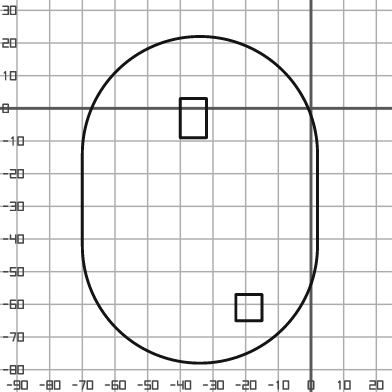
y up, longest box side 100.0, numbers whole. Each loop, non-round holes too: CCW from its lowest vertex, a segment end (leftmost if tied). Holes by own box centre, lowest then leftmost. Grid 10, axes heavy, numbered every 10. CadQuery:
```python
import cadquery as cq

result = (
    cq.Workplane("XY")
    .moveTo(-70.0, -42.0)
    .threePointArc((-34.0, -78.0), (2.0, -42.0))
    .lineTo(2.0, -14.0)
    .threePointArc((-34.0, 22.0), (-70.0, -14.0))
    .close()
    .moveTo(-23.0, -65.0)
    .lineTo(-15.0, -65.0)
    .lineTo(-15.0, -57.0)
    .lineTo(-23.0, -57.0)
    .close()
    .moveTo(-40.0, -9.0)
    .lineTo(-32.0, -9.0)
    .lineTo(-32.0, 3.0)
    .lineTo(-40.0, 3.0)
    .close()
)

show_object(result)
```